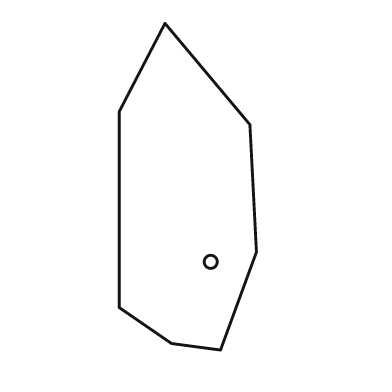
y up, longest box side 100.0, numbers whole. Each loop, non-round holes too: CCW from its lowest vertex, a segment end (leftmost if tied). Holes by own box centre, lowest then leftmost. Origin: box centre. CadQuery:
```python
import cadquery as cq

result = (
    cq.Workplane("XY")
    .moveTo(10.0, -50.0)
    .lineTo(21.0, -20.0)
    .lineTo(19.0, 19.0)
    .lineTo(-7.0, 50.0)
    .lineTo(-21.0, 23.0)
    .lineTo(-21.0, -37.0)
    .lineTo(-5.0, -48.0)
    .close()
    .moveTo(7.0, -23.0)
    .circle(2.0)
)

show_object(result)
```